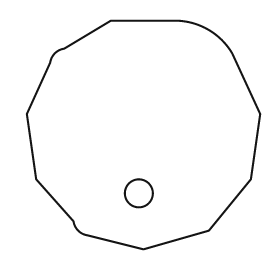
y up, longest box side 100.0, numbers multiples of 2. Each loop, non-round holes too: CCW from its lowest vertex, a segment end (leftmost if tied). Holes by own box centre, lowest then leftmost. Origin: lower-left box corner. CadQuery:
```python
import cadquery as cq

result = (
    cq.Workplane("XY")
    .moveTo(50.0, 0.0)
    .lineTo(78.0, 8.0)
    .lineTo(96.0, 30.0)
    .lineTo(100.0, 58.0)
    .lineTo(88.0, 84.0)
    .threePointArc((78.0, 94.0), (64.0, 98.0))
    .lineTo(36.0, 98.0)
    .lineTo(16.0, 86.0)
    .threePointArc((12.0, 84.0), (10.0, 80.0))
    .lineTo(0.0, 58.0)
    .lineTo(4.0, 30.0)
    .lineTo(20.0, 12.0)
    .threePointArc((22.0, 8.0), (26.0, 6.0))
    .close()
    .moveTo(48.0, 24.0)
    .circle(6.0)
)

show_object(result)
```